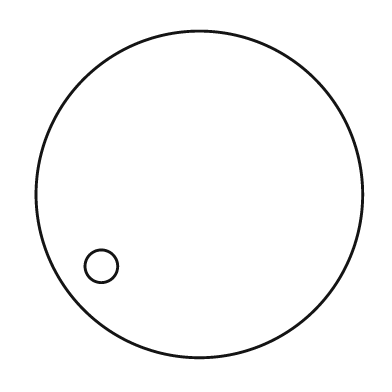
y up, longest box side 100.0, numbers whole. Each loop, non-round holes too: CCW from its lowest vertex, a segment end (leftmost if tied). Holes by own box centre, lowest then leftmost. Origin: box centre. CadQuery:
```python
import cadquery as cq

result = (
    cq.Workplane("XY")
    .moveTo(0.0, 0.0)
    .circle(50.0)
    .moveTo(-30.0, -22.0)
    .circle(5.0)
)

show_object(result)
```